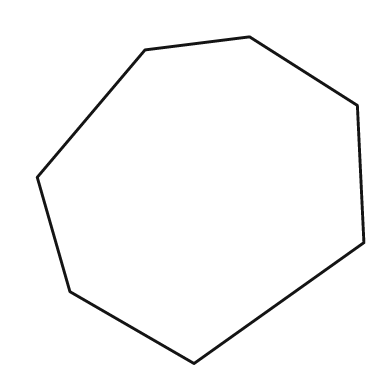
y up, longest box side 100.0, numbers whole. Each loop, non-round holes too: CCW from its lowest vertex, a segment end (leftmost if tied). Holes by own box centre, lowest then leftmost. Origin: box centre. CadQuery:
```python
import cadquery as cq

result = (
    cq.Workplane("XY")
    .moveTo(-2.0, -50.0)
    .lineTo(50.0, -13.0)
    .lineTo(48.0, 29.0)
    .lineTo(15.0, 50.0)
    .lineTo(-17.0, 46.0)
    .lineTo(-50.0, 7.0)
    .lineTo(-40.0, -28.0)
    .close()
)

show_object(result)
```